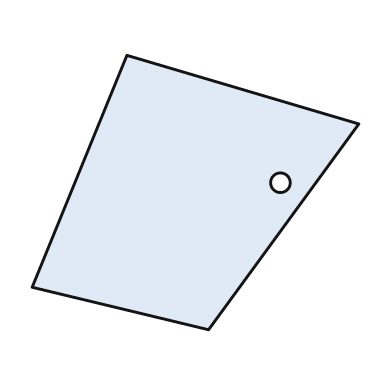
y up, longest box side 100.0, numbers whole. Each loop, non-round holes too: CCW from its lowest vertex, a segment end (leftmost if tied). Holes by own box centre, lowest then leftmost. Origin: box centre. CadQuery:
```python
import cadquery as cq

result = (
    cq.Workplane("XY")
    .moveTo(4.0, -42.0)
    .lineTo(50.0, 21.0)
    .lineTo(-21.0, 42.0)
    .lineTo(-50.0, -29.0)
    .close()
    .moveTo(26.0, 3.0)
    .circle(3.0)
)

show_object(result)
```